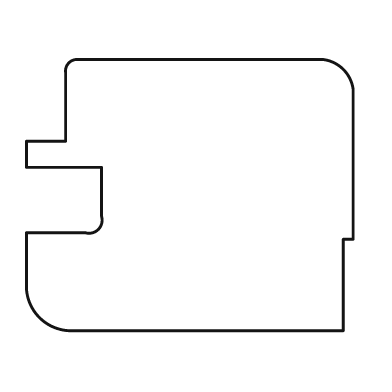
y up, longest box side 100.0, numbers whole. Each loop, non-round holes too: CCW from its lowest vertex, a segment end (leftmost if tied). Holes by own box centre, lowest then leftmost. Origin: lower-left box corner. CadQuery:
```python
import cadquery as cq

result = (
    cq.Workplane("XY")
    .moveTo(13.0, 0.0)
    .lineTo(97.0, 0.0)
    .lineTo(97.0, 28.0)
    .lineTo(100.0, 28.0)
    .lineTo(100.0, 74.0)
    .threePointArc((97.0, 80.0), (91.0, 83.0))
    .lineTo(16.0, 83.0)
    .threePointArc((13.0, 82.0), (12.0, 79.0))
    .lineTo(12.0, 58.0)
    .lineTo(0.0, 58.0)
    .lineTo(0.0, 50.0)
    .lineTo(23.0, 50.0)
    .lineTo(23.0, 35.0)
    .threePointArc((22.0, 31.0), (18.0, 30.0))
    .lineTo(0.0, 30.0)
    .lineTo(0.0, 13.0)
    .threePointArc((4.0, 4.0), (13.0, 0.0))
    .close()
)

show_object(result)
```